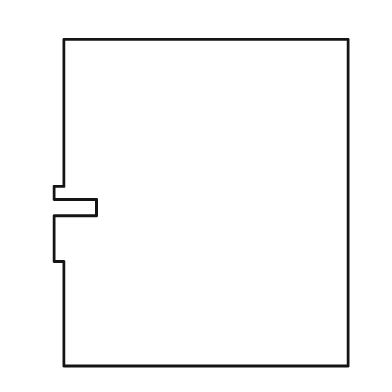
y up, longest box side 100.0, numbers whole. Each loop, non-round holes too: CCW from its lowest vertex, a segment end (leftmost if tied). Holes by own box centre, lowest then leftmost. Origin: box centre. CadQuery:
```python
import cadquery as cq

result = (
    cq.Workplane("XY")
    .moveTo(-42.0, -50.0)
    .lineTo(45.0, -50.0)
    .lineTo(45.0, 50.0)
    .lineTo(-42.0, 50.0)
    .lineTo(-42.0, 5.0)
    .lineTo(-45.0, 5.0)
    .lineTo(-45.0, 1.0)
    .lineTo(-32.0, 1.0)
    .lineTo(-32.0, -4.0)
    .lineTo(-45.0, -4.0)
    .lineTo(-45.0, -18.0)
    .lineTo(-42.0, -18.0)
    .close()
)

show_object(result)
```